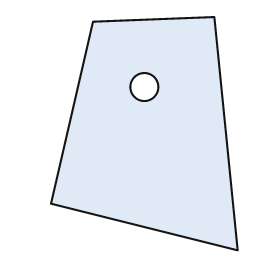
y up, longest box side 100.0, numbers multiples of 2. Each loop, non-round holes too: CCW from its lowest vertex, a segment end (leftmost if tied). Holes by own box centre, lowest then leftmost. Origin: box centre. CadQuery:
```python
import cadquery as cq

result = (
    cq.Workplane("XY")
    .moveTo(40.0, -50.0)
    .lineTo(30.0, 50.0)
    .lineTo(-22.0, 48.0)
    .lineTo(-40.0, -30.0)
    .close()
    .moveTo(0.0, 20.0)
    .circle(6.0)
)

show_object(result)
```